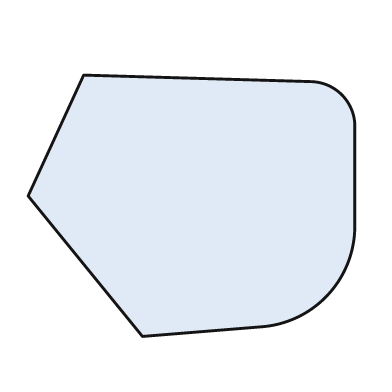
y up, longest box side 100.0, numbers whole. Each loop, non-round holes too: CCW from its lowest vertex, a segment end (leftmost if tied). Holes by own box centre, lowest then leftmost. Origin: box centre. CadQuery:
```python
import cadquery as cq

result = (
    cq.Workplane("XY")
    .moveTo(-15.0, -40.0)
    .lineTo(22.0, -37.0)
    .threePointArc((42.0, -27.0), (50.0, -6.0))
    .lineTo(50.0, 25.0)
    .threePointArc((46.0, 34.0), (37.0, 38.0))
    .lineTo(-33.0, 40.0)
    .lineTo(-50.0, 3.0)
    .close()
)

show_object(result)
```